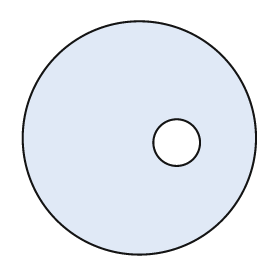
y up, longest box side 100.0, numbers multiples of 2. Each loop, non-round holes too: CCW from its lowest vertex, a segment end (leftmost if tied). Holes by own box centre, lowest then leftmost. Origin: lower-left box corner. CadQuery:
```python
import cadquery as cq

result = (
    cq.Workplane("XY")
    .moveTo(50.0, 50.0)
    .circle(50.0)
    .moveTo(66.0, 48.0)
    .circle(10.0)
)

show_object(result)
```